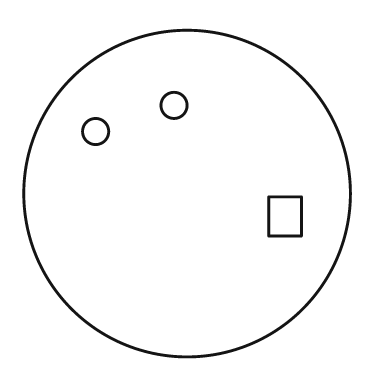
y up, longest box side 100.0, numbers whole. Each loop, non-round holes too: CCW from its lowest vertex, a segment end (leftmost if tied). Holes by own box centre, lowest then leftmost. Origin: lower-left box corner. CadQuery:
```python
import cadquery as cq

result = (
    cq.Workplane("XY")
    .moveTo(50.0, 50.0)
    .circle(50.0)
    .moveTo(75.0, 37.0)
    .lineTo(85.0, 37.0)
    .lineTo(85.0, 49.0)
    .lineTo(75.0, 49.0)
    .close()
    .moveTo(22.0, 69.0)
    .circle(4.0)
    .moveTo(46.0, 77.0)
    .circle(4.0)
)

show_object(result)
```